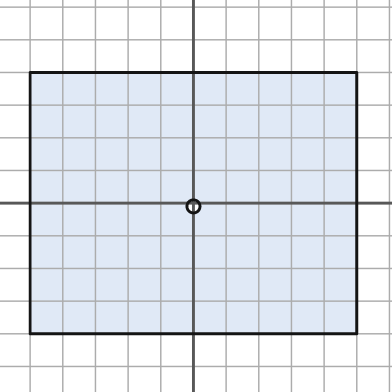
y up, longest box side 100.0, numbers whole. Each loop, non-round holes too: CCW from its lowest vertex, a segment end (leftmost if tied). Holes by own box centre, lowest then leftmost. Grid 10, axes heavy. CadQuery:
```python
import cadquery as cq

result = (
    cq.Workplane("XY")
    .moveTo(-50.0, -40.0)
    .lineTo(50.0, -40.0)
    .lineTo(50.0, 40.0)
    .lineTo(-50.0, 40.0)
    .close()
    .moveTo(0.0, -1.0)
    .circle(2.0)
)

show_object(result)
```